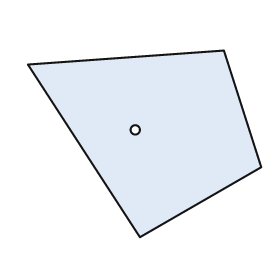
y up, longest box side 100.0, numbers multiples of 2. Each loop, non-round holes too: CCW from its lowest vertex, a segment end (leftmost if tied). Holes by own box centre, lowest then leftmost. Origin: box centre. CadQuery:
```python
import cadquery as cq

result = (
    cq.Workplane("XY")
    .moveTo(-2.0, -40.0)
    .lineTo(50.0, -10.0)
    .lineTo(34.0, 40.0)
    .lineTo(-50.0, 34.0)
    .close()
    .moveTo(-4.0, 6.0)
    .circle(2.0)
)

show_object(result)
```